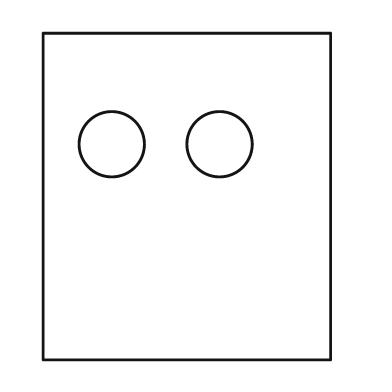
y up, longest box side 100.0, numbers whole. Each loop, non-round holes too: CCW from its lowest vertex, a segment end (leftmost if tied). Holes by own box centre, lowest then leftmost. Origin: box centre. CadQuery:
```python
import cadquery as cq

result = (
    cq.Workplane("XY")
    .moveTo(-44.0, -50.0)
    .lineTo(44.0, -50.0)
    .lineTo(44.0, 50.0)
    .lineTo(-44.0, 50.0)
    .close()
    .moveTo(-23.0, 16.0)
    .circle(10.0)
    .moveTo(10.0, 16.0)
    .circle(10.0)
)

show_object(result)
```